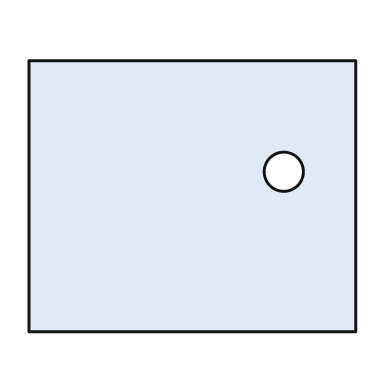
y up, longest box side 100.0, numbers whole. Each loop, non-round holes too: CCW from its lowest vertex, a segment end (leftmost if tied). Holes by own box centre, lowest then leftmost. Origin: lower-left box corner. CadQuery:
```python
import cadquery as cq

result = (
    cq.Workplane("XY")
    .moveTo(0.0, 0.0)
    .lineTo(100.0, 0.0)
    .lineTo(100.0, 83.0)
    .lineTo(0.0, 83.0)
    .close()
    .moveTo(78.0, 49.0)
    .circle(6.0)
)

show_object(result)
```